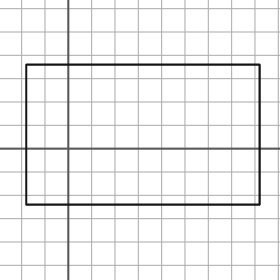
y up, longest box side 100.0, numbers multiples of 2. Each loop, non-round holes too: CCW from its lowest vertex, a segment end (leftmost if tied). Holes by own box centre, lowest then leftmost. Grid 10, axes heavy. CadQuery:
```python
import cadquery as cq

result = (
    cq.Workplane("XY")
    .moveTo(-18.0, -24.0)
    .lineTo(82.0, -24.0)
    .lineTo(82.0, 36.0)
    .lineTo(-18.0, 36.0)
    .close()
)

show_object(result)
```